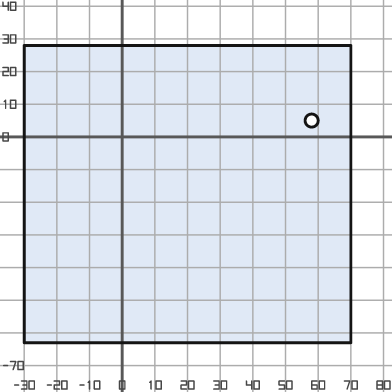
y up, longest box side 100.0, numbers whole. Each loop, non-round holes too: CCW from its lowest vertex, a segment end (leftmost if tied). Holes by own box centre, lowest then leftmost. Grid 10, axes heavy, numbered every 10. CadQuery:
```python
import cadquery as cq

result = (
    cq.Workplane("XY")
    .moveTo(-30.0, -63.0)
    .lineTo(70.0, -63.0)
    .lineTo(70.0, 28.0)
    .lineTo(-30.0, 28.0)
    .close()
    .moveTo(58.0, 5.0)
    .circle(2.0)
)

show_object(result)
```